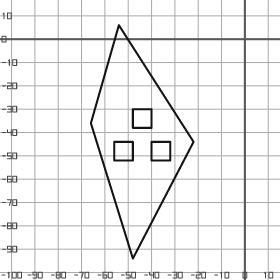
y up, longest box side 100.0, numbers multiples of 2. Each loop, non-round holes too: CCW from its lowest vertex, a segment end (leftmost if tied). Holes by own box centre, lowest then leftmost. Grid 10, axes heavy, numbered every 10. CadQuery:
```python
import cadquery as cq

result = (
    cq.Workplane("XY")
    .moveTo(-48.0, -94.0)
    .lineTo(-22.0, -44.0)
    .lineTo(-54.0, 6.0)
    .lineTo(-66.0, -36.0)
    .close()
    .moveTo(-56.0, -52.0)
    .lineTo(-48.0, -52.0)
    .lineTo(-48.0, -44.0)
    .lineTo(-56.0, -44.0)
    .close()
    .moveTo(-40.0, -52.0)
    .lineTo(-32.0, -52.0)
    .lineTo(-32.0, -44.0)
    .lineTo(-40.0, -44.0)
    .close()
    .moveTo(-48.0, -38.0)
    .lineTo(-40.0, -38.0)
    .lineTo(-40.0, -30.0)
    .lineTo(-48.0, -30.0)
    .close()
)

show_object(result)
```